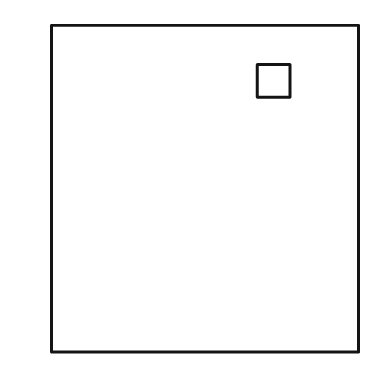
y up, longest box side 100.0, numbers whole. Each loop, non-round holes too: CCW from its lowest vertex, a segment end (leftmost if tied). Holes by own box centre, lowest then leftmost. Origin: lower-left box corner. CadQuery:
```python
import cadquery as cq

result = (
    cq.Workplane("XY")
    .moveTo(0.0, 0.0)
    .lineTo(94.0, 0.0)
    .lineTo(94.0, 100.0)
    .lineTo(0.0, 100.0)
    .close()
    .moveTo(63.0, 78.0)
    .lineTo(73.0, 78.0)
    .lineTo(73.0, 88.0)
    .lineTo(63.0, 88.0)
    .close()
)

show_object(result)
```